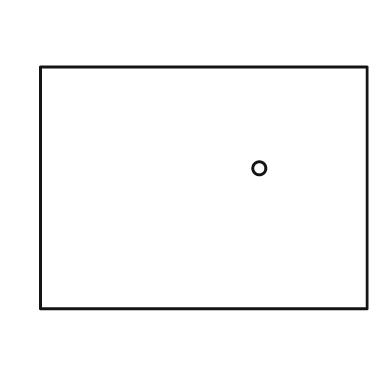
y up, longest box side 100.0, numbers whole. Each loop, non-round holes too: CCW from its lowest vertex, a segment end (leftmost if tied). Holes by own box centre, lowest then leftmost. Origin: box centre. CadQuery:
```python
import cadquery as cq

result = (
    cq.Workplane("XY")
    .moveTo(-50.0, -37.0)
    .lineTo(50.0, -37.0)
    .lineTo(50.0, 37.0)
    .lineTo(-50.0, 37.0)
    .close()
    .moveTo(17.0, 6.0)
    .circle(2.0)
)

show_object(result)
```